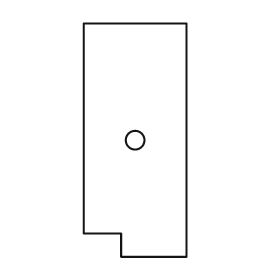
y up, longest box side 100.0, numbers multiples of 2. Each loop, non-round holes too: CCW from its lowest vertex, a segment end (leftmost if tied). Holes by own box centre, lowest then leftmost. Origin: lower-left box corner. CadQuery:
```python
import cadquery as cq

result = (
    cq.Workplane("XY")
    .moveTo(16.0, 0.0)
    .lineTo(44.0, 0.0)
    .lineTo(44.0, 100.0)
    .lineTo(0.0, 100.0)
    .lineTo(0.0, 10.0)
    .lineTo(16.0, 10.0)
    .close()
    .moveTo(22.0, 50.0)
    .circle(4.0)
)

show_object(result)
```